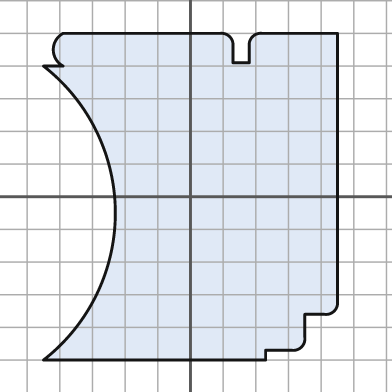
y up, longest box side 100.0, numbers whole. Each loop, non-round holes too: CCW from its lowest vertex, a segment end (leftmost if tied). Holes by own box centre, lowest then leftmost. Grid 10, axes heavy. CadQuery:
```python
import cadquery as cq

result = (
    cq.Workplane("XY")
    .moveTo(-45.0, -50.0)
    .lineTo(23.0, -50.0)
    .lineTo(23.0, -47.0)
    .lineTo(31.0, -47.0)
    .threePointArc((34.0, -46.0), (35.0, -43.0))
    .lineTo(35.0, -36.0)
    .lineTo(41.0, -36.0)
    .threePointArc((44.0, -35.0), (45.0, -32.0))
    .lineTo(45.0, 50.0)
    .lineTo(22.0, 50.0)
    .threePointArc((19.0, 49.0), (18.0, 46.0))
    .lineTo(18.0, 41.0)
    .lineTo(13.0, 41.0)
    .lineTo(13.0, 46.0)
    .threePointArc((12.0, 49.0), (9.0, 50.0))
    .lineTo(-39.0, 50.0)
    .threePointArc((-42.0, 45.0), (-39.0, 40.0))
    .lineTo(-45.0, 40.0)
    .threePointArc((-23.0, -5.0), (-45.0, -50.0))
    .close()
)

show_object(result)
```